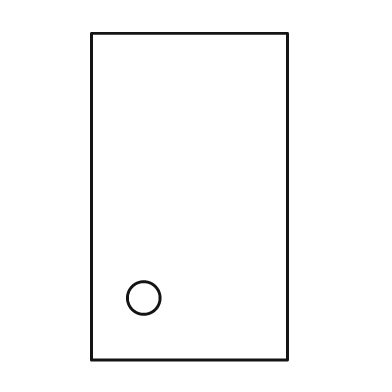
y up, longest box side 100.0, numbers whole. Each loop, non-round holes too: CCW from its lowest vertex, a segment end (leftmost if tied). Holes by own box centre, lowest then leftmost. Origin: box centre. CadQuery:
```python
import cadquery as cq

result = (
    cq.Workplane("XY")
    .moveTo(-30.0, -50.0)
    .lineTo(30.0, -50.0)
    .lineTo(30.0, 50.0)
    .lineTo(-30.0, 50.0)
    .close()
    .moveTo(-14.0, -31.0)
    .circle(5.0)
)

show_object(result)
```